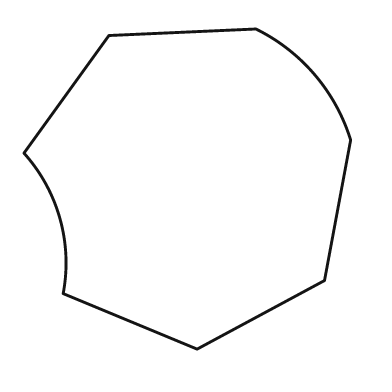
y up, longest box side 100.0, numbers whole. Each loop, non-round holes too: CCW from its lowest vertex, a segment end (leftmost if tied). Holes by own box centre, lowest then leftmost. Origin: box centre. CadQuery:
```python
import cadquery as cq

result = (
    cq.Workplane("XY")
    .moveTo(3.0, -49.0)
    .lineTo(42.0, -28.0)
    .lineTo(50.0, 15.0)
    .threePointArc((39.0, 35.0), (21.0, 49.0))
    .lineTo(-24.0, 47.0)
    .lineTo(-50.0, 11.0)
    .threePointArc((-39.0, -9.0), (-38.0, -32.0))
    .close()
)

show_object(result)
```